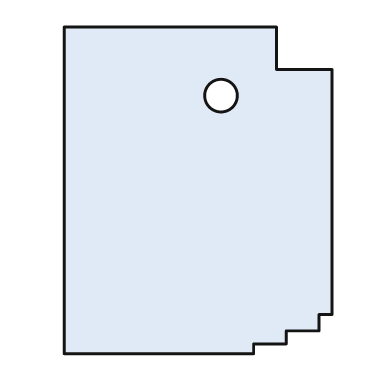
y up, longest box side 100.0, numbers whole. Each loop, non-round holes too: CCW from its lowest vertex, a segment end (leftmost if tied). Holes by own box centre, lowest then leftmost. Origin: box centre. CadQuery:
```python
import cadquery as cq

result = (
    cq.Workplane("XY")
    .moveTo(-41.0, -50.0)
    .lineTo(17.0, -50.0)
    .lineTo(17.0, -47.0)
    .lineTo(27.0, -47.0)
    .lineTo(27.0, -43.0)
    .lineTo(37.0, -43.0)
    .lineTo(37.0, -38.0)
    .lineTo(41.0, -38.0)
    .lineTo(41.0, 37.0)
    .lineTo(24.0, 37.0)
    .lineTo(24.0, 50.0)
    .lineTo(-41.0, 50.0)
    .close()
    .moveTo(7.0, 29.0)
    .circle(5.0)
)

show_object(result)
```